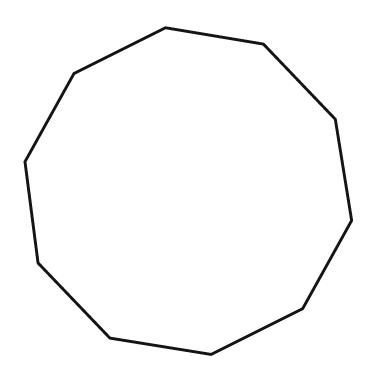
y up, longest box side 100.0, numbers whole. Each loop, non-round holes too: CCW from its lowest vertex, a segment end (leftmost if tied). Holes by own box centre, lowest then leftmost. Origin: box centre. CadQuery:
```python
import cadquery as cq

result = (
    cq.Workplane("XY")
    .moveTo(7.0, -50.0)
    .lineTo(35.0, -36.0)
    .lineTo(50.0, -9.0)
    .lineTo(45.0, 22.0)
    .lineTo(23.0, 45.0)
    .lineTo(-7.0, 50.0)
    .lineTo(-35.0, 36.0)
    .lineTo(-50.0, 9.0)
    .lineTo(-46.0, -22.0)
    .lineTo(-24.0, -45.0)
    .close()
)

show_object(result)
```